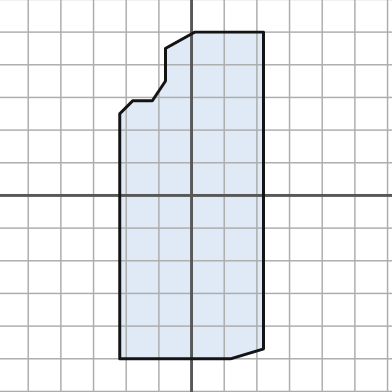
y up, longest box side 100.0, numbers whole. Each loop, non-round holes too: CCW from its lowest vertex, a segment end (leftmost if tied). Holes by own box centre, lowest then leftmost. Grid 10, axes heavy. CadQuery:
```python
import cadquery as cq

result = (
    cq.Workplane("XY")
    .moveTo(-22.0, -50.0)
    .lineTo(12.0, -50.0)
    .lineTo(22.0, -47.0)
    .lineTo(22.0, 50.0)
    .lineTo(1.0, 50.0)
    .lineTo(-8.0, 45.0)
    .lineTo(-8.0, 35.0)
    .lineTo(-12.0, 29.0)
    .lineTo(-18.0, 29.0)
    .lineTo(-22.0, 25.0)
    .close()
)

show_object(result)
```